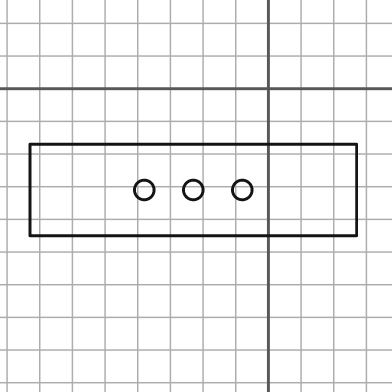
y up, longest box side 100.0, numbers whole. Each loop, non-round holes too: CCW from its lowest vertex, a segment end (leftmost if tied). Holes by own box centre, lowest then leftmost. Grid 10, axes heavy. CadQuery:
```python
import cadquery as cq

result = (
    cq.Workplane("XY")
    .moveTo(-73.0, -45.0)
    .lineTo(27.0, -45.0)
    .lineTo(27.0, -17.0)
    .lineTo(-73.0, -17.0)
    .close()
    .moveTo(-38.0, -31.0)
    .circle(3.0)
    .moveTo(-23.0, -31.0)
    .circle(3.0)
    .moveTo(-8.0, -31.0)
    .circle(3.0)
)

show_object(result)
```